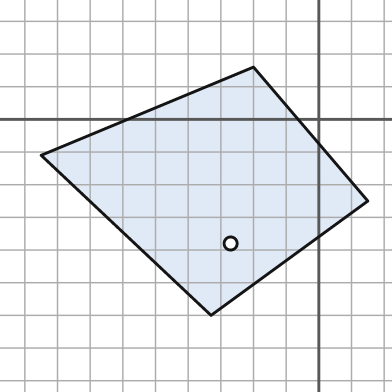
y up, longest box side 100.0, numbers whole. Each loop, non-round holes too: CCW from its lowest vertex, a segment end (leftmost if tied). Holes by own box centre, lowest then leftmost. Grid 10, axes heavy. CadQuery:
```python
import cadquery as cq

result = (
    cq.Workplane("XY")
    .moveTo(-33.0, -60.0)
    .lineTo(15.0, -25.0)
    .lineTo(-20.0, 16.0)
    .lineTo(-85.0, -11.0)
    .close()
    .moveTo(-27.0, -38.0)
    .circle(2.0)
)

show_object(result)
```